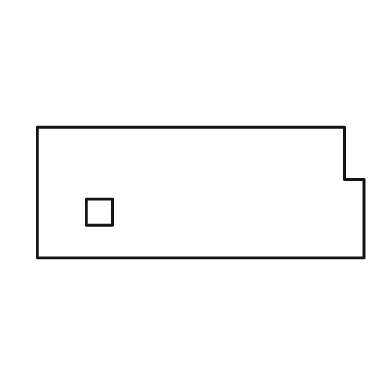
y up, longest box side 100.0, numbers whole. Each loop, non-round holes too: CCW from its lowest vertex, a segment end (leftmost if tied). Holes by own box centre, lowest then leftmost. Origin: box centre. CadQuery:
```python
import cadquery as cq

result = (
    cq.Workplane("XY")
    .moveTo(-50.0, -20.0)
    .lineTo(50.0, -20.0)
    .lineTo(50.0, 4.0)
    .lineTo(44.0, 4.0)
    .lineTo(44.0, 20.0)
    .lineTo(-50.0, 20.0)
    .close()
    .moveTo(-35.0, -10.0)
    .lineTo(-27.0, -10.0)
    .lineTo(-27.0, -2.0)
    .lineTo(-35.0, -2.0)
    .close()
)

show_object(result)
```